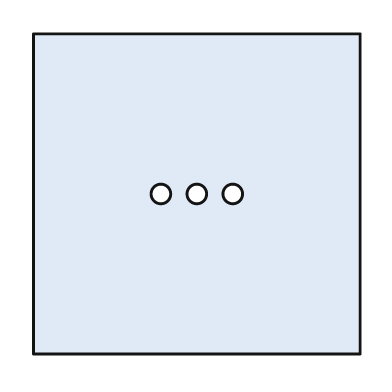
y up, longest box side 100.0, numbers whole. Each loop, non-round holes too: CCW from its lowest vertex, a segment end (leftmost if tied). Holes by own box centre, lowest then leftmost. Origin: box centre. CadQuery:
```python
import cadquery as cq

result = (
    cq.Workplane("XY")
    .moveTo(-50.0, -49.0)
    .lineTo(50.0, -49.0)
    .lineTo(50.0, 49.0)
    .lineTo(-50.0, 49.0)
    .close()
    .moveTo(-11.0, 0.0)
    .circle(3.0)
    .moveTo(0.0, 0.0)
    .circle(3.0)
    .moveTo(11.0, 0.0)
    .circle(3.0)
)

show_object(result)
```